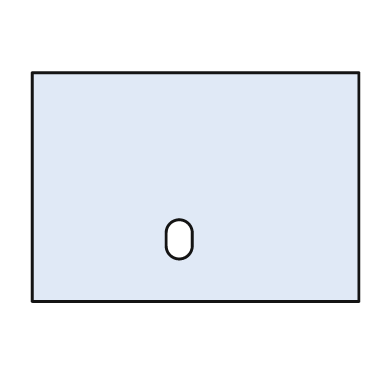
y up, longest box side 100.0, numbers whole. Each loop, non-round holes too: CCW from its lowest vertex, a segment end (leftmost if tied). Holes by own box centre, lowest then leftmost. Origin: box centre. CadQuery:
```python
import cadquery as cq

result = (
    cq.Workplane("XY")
    .moveTo(-50.0, -35.0)
    .lineTo(50.0, -35.0)
    .lineTo(50.0, 35.0)
    .lineTo(-50.0, 35.0)
    .close()
    .moveTo(-9.0, -18.0)
    .threePointArc((-5.0, -22.0), (-1.0, -18.0))
    .lineTo(-1.0, -14.0)
    .threePointArc((-5.0, -10.0), (-9.0, -14.0))
    .close()
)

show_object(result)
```